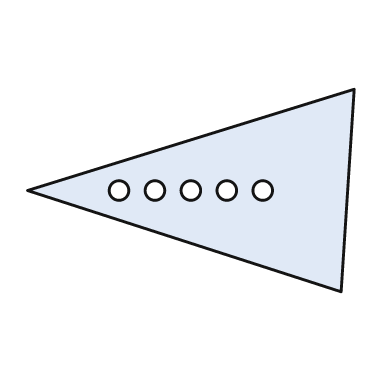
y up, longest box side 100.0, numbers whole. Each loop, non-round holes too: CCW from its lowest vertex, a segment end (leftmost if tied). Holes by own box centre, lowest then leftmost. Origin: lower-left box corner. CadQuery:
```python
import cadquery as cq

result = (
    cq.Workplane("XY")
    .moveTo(96.0, 0.0)
    .lineTo(100.0, 62.0)
    .lineTo(0.0, 31.0)
    .close()
    .moveTo(28.0, 31.0)
    .circle(3.0)
    .moveTo(39.0, 31.0)
    .circle(3.0)
    .moveTo(50.0, 31.0)
    .circle(3.0)
    .moveTo(61.0, 31.0)
    .circle(3.0)
    .moveTo(72.0, 31.0)
    .circle(3.0)
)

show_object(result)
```